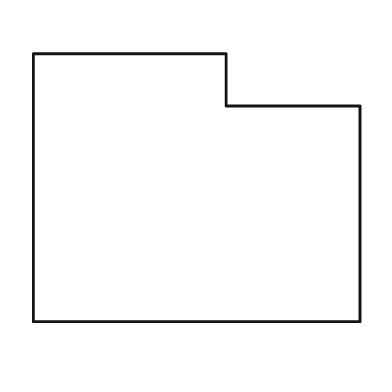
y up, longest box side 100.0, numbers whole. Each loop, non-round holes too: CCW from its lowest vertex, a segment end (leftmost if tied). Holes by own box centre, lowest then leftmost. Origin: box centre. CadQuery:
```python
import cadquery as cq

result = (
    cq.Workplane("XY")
    .moveTo(-50.0, -41.0)
    .lineTo(50.0, -41.0)
    .lineTo(50.0, 25.0)
    .lineTo(9.0, 25.0)
    .lineTo(9.0, 41.0)
    .lineTo(-50.0, 41.0)
    .close()
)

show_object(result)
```